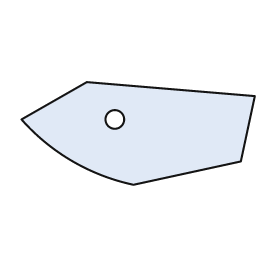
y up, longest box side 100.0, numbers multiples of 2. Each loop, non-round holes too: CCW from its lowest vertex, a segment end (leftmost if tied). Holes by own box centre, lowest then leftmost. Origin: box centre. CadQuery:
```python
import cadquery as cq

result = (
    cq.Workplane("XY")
    .moveTo(-2.0, -22.0)
    .lineTo(44.0, -12.0)
    .lineTo(50.0, 16.0)
    .lineTo(-22.0, 22.0)
    .lineTo(-50.0, 6.0)
    .threePointArc((-28.0, -12.0), (-2.0, -22.0))
    .close()
    .moveTo(-10.0, 6.0)
    .circle(4.0)
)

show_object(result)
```